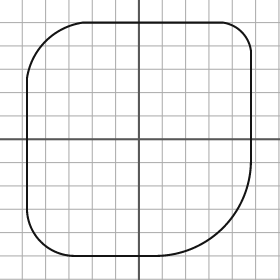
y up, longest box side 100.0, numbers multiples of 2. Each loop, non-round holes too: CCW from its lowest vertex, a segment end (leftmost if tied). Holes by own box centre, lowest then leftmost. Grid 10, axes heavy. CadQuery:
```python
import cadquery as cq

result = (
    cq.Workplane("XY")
    .moveTo(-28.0, -50.0)
    .lineTo(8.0, -50.0)
    .threePointArc((36.0, -38.0), (48.0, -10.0))
    .lineTo(48.0, 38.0)
    .threePointArc((44.0, 46.0), (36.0, 50.0))
    .lineTo(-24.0, 50.0)
    .threePointArc((-40.0, 42.0), (-48.0, 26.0))
    .lineTo(-48.0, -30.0)
    .threePointArc((-42.0, -44.0), (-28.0, -50.0))
    .close()
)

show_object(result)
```